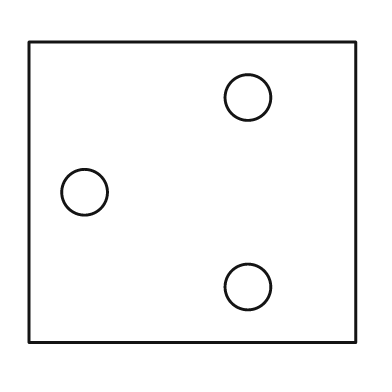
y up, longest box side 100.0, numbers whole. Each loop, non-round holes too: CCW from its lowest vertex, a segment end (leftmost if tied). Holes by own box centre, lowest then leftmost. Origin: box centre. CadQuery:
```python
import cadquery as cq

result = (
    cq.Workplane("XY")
    .moveTo(-50.0, -46.0)
    .lineTo(50.0, -46.0)
    .lineTo(50.0, 46.0)
    .lineTo(-50.0, 46.0)
    .close()
    .moveTo(17.0, -29.0)
    .circle(7.0)
    .moveTo(-33.0, 0.0)
    .circle(7.0)
    .moveTo(17.0, 29.0)
    .circle(7.0)
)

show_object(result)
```